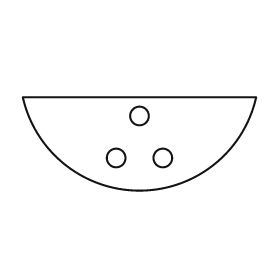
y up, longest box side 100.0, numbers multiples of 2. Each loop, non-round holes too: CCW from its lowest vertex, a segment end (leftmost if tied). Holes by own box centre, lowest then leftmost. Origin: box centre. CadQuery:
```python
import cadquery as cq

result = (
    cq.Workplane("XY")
    .moveTo(-50.0, 20.0)
    .threePointArc((0.0, -20.0), (50.0, 20.0))
    .close()
    .moveTo(-10.0, -6.0)
    .circle(4.0)
    .moveTo(10.0, -6.0)
    .circle(4.0)
    .moveTo(0.0, 12.0)
    .circle(4.0)
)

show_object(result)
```